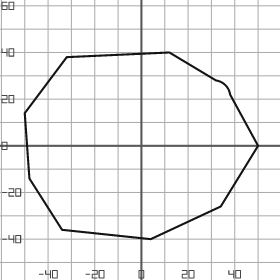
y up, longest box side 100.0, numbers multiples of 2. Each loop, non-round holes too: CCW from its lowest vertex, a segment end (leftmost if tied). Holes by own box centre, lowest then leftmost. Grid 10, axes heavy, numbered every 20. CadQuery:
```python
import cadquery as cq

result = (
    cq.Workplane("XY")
    .moveTo(4.0, -40.0)
    .lineTo(34.0, -26.0)
    .lineTo(50.0, 0.0)
    .lineTo(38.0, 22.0)
    .threePointArc((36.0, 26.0), (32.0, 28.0))
    .lineTo(12.0, 40.0)
    .lineTo(-32.0, 38.0)
    .lineTo(-50.0, 14.0)
    .lineTo(-48.0, -14.0)
    .lineTo(-34.0, -36.0)
    .close()
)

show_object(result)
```